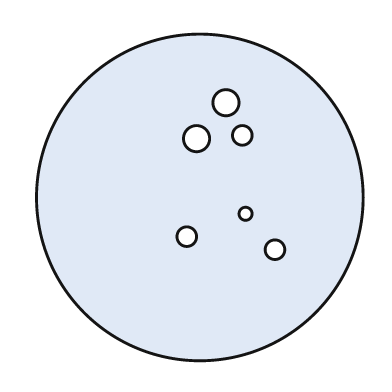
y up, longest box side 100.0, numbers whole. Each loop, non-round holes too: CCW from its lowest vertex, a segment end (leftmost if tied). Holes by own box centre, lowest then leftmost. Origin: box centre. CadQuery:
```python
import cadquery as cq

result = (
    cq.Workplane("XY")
    .moveTo(0.0, 0.0)
    .circle(50.0)
    .moveTo(23.0, -16.0)
    .circle(3.0)
    .moveTo(-4.0, -12.0)
    .circle(3.0)
    .moveTo(14.0, -5.0)
    .circle(2.0)
    .moveTo(-1.0, 18.0)
    .circle(4.0)
    .moveTo(13.0, 19.0)
    .circle(3.0)
    .moveTo(8.0, 29.0)
    .circle(4.0)
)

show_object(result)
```